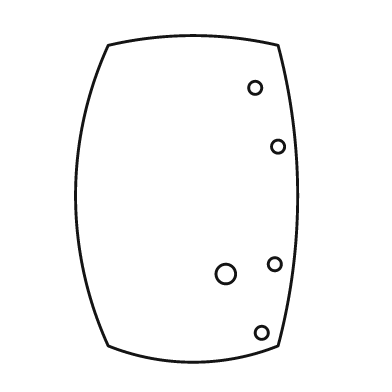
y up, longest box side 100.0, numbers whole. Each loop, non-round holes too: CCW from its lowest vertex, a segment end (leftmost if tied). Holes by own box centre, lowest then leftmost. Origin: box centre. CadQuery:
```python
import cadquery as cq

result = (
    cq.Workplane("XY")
    .moveTo(-24.0, -45.0)
    .threePointArc((2.0, -50.0), (28.0, -45.0))
    .threePointArc((34.0, 1.0), (28.0, 47.0))
    .threePointArc((2.0, 50.0), (-24.0, 47.0))
    .threePointArc((-34.0, 1.0), (-24.0, -45.0))
    .close()
    .moveTo(23.0, -41.0)
    .circle(2.0)
    .moveTo(12.0, -23.0)
    .circle(3.0)
    .moveTo(27.0, -20.0)
    .circle(2.0)
    .moveTo(28.0, 16.0)
    .circle(2.0)
    .moveTo(21.0, 34.0)
    .circle(2.0)
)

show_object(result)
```